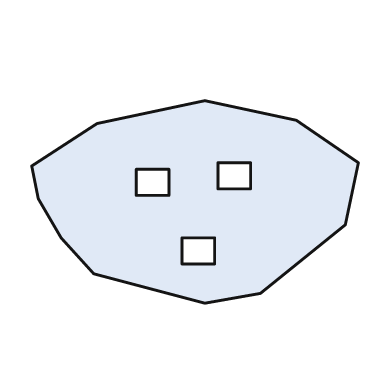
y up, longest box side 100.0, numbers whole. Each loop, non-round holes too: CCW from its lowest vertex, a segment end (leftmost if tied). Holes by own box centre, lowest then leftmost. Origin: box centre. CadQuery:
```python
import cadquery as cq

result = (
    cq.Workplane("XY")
    .moveTo(3.0, -31.0)
    .lineTo(20.0, -28.0)
    .lineTo(46.0, -7.0)
    .lineTo(50.0, 12.0)
    .lineTo(31.0, 25.0)
    .lineTo(3.0, 31.0)
    .lineTo(-30.0, 24.0)
    .lineTo(-50.0, 11.0)
    .lineTo(-48.0, 1.0)
    .lineTo(-41.0, -11.0)
    .lineTo(-31.0, -22.0)
    .close()
    .moveTo(-4.0, -19.0)
    .lineTo(6.0, -19.0)
    .lineTo(6.0, -11.0)
    .lineTo(-4.0, -11.0)
    .close()
    .moveTo(-18.0, 2.0)
    .lineTo(-8.0, 2.0)
    .lineTo(-8.0, 10.0)
    .lineTo(-18.0, 10.0)
    .close()
    .moveTo(7.0, 4.0)
    .lineTo(17.0, 4.0)
    .lineTo(17.0, 12.0)
    .lineTo(7.0, 12.0)
    .close()
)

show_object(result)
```